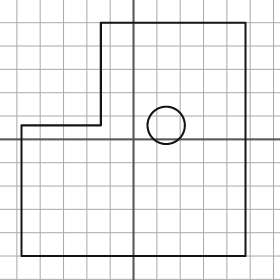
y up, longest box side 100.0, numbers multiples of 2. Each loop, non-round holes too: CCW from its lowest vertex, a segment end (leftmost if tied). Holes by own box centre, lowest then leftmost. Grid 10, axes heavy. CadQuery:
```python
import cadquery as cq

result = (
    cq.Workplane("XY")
    .moveTo(-48.0, -50.0)
    .lineTo(48.0, -50.0)
    .lineTo(48.0, 50.0)
    .lineTo(-14.0, 50.0)
    .lineTo(-14.0, 6.0)
    .lineTo(-48.0, 6.0)
    .close()
    .moveTo(14.0, 6.0)
    .circle(8.0)
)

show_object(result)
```